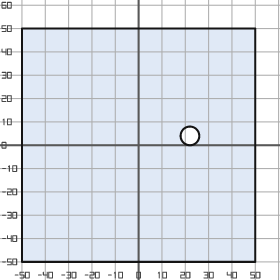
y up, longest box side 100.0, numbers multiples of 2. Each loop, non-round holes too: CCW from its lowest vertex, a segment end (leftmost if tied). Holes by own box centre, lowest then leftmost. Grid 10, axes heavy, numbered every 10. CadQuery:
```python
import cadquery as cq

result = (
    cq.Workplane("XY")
    .moveTo(-50.0, -50.0)
    .lineTo(50.0, -50.0)
    .lineTo(50.0, 50.0)
    .lineTo(-50.0, 50.0)
    .close()
    .moveTo(22.0, 4.0)
    .circle(4.0)
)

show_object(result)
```